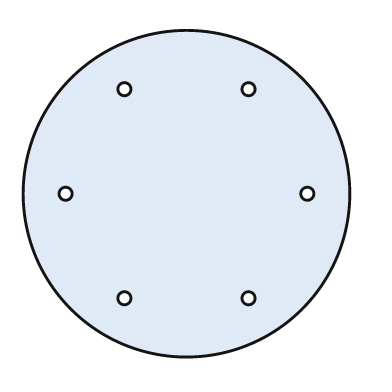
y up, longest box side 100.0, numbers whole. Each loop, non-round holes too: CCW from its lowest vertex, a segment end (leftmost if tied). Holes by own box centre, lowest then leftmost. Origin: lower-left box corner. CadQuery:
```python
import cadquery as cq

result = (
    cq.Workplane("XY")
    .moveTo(50.0, 50.0)
    .circle(50.0)
    .moveTo(31.0, 18.0)
    .circle(2.0)
    .moveTo(69.0, 18.0)
    .circle(2.0)
    .moveTo(13.0, 50.0)
    .circle(2.0)
    .moveTo(87.0, 50.0)
    .circle(2.0)
    .moveTo(31.0, 82.0)
    .circle(2.0)
    .moveTo(69.0, 82.0)
    .circle(2.0)
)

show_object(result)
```